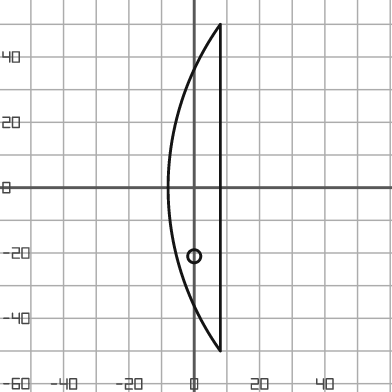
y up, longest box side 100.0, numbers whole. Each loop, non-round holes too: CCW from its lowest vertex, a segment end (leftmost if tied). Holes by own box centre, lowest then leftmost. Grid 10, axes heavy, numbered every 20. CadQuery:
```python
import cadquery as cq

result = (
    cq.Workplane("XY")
    .moveTo(8.0, -50.0)
    .lineTo(8.0, 50.0)
    .threePointArc((-8.0, 0.0), (8.0, -50.0))
    .close()
    .moveTo(0.0, -21.0)
    .circle(2.0)
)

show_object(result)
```